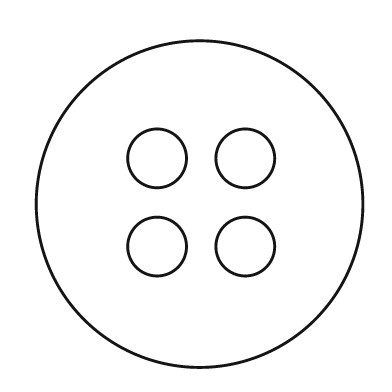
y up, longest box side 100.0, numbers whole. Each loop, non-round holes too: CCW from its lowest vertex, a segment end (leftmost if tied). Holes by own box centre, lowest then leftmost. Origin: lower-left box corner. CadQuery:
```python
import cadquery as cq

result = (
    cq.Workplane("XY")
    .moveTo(50.0, 50.0)
    .circle(50.0)
    .moveTo(37.0, 37.0)
    .circle(9.0)
    .moveTo(64.0, 37.0)
    .circle(9.0)
    .moveTo(37.0, 64.0)
    .circle(9.0)
    .moveTo(64.0, 64.0)
    .circle(9.0)
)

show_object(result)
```